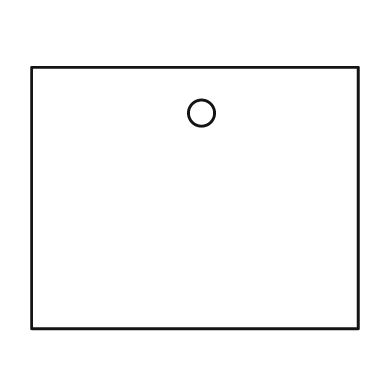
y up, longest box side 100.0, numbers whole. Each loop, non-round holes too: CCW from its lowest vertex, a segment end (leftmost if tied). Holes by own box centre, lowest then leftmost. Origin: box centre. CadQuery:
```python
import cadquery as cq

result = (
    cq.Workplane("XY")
    .moveTo(-50.0, -40.0)
    .lineTo(50.0, -40.0)
    .lineTo(50.0, 40.0)
    .lineTo(-50.0, 40.0)
    .close()
    .moveTo(2.0, 26.0)
    .circle(4.0)
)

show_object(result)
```